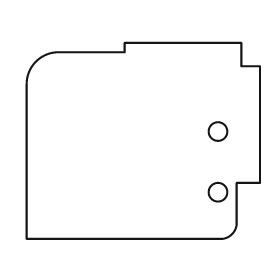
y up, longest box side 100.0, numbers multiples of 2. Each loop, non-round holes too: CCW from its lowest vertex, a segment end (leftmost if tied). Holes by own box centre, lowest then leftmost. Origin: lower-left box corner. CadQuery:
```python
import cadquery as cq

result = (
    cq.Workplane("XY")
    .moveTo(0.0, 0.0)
    .lineTo(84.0, 0.0)
    .threePointArc((88.0, 2.0), (90.0, 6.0))
    .lineTo(90.0, 24.0)
    .lineTo(100.0, 24.0)
    .lineTo(100.0, 74.0)
    .lineTo(92.0, 74.0)
    .lineTo(92.0, 84.0)
    .lineTo(42.0, 84.0)
    .lineTo(42.0, 80.0)
    .lineTo(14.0, 80.0)
    .threePointArc((4.0, 76.0), (0.0, 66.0))
    .close()
    .moveTo(82.0, 20.0)
    .circle(4.0)
    .moveTo(82.0, 46.0)
    .circle(4.0)
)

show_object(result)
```